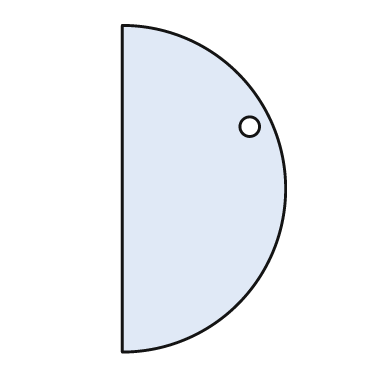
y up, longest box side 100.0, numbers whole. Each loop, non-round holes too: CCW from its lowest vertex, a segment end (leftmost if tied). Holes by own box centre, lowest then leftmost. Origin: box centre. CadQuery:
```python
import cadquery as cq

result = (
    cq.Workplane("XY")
    .moveTo(-25.0, -50.0)
    .threePointArc((25.0, 0.0), (-25.0, 50.0))
    .close()
    .moveTo(14.0, 19.0)
    .circle(3.0)
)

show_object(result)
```